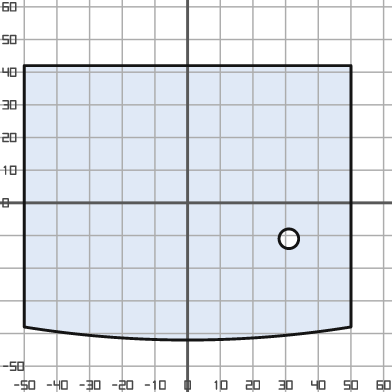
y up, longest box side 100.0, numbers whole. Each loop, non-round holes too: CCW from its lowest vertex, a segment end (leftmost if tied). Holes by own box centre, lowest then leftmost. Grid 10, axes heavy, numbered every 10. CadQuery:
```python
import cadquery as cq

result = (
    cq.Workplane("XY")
    .moveTo(-50.0, -38.0)
    .threePointArc((0.0, -42.0), (50.0, -38.0))
    .lineTo(50.0, 42.0)
    .lineTo(-50.0, 42.0)
    .close()
    .moveTo(31.0, -11.0)
    .circle(3.0)
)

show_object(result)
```